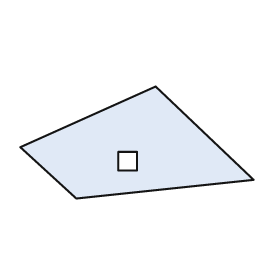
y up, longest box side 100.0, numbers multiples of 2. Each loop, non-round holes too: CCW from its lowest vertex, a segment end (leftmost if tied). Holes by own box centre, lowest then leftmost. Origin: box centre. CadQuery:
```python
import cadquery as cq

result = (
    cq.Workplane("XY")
    .moveTo(-26.0, -24.0)
    .lineTo(50.0, -16.0)
    .lineTo(8.0, 24.0)
    .lineTo(-50.0, -2.0)
    .close()
    .moveTo(-8.0, -12.0)
    .lineTo(0.0, -12.0)
    .lineTo(0.0, -4.0)
    .lineTo(-8.0, -4.0)
    .close()
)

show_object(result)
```